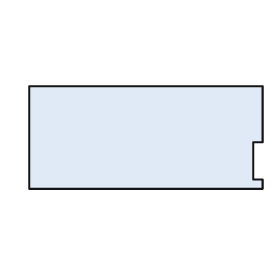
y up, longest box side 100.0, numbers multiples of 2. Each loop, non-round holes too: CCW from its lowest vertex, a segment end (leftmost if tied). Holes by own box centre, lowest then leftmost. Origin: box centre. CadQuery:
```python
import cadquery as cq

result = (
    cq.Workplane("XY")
    .moveTo(-50.0, -22.0)
    .lineTo(50.0, -22.0)
    .lineTo(50.0, -18.0)
    .lineTo(46.0, -18.0)
    .lineTo(46.0, -2.0)
    .lineTo(50.0, -2.0)
    .lineTo(50.0, 22.0)
    .lineTo(-50.0, 22.0)
    .close()
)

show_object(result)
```